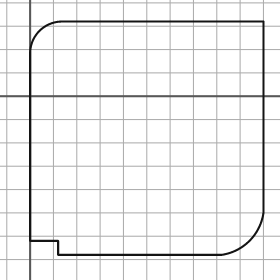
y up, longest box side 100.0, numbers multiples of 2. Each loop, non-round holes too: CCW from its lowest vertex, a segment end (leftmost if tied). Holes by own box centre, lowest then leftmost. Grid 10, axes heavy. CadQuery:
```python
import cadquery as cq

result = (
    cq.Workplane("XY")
    .moveTo(12.0, -68.0)
    .lineTo(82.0, -68.0)
    .threePointArc((94.0, -62.0), (100.0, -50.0))
    .lineTo(100.0, 32.0)
    .lineTo(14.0, 32.0)
    .threePointArc((4.0, 28.0), (0.0, 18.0))
    .lineTo(0.0, -62.0)
    .lineTo(12.0, -62.0)
    .close()
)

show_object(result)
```